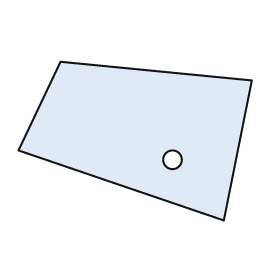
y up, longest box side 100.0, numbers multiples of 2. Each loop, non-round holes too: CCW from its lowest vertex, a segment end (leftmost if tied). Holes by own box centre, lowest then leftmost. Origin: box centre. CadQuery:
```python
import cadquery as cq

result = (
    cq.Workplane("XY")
    .moveTo(38.0, -34.0)
    .lineTo(50.0, 26.0)
    .lineTo(-32.0, 34.0)
    .lineTo(-50.0, -4.0)
    .close()
    .moveTo(16.0, -8.0)
    .circle(4.0)
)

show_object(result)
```